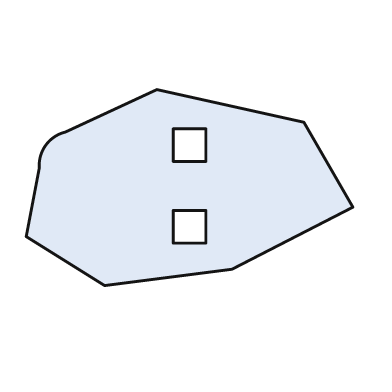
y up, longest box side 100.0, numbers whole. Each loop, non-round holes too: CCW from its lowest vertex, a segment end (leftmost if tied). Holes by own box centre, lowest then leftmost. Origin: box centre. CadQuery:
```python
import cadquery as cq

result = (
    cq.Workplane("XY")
    .moveTo(-26.0, -30.0)
    .lineTo(13.0, -25.0)
    .lineTo(50.0, -6.0)
    .lineTo(35.0, 20.0)
    .lineTo(-10.0, 30.0)
    .lineTo(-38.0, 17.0)
    .threePointArc((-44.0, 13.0), (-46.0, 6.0))
    .lineTo(-50.0, -15.0)
    .close()
    .moveTo(-5.0, -17.0)
    .lineTo(5.0, -17.0)
    .lineTo(5.0, -7.0)
    .lineTo(-5.0, -7.0)
    .close()
    .moveTo(-5.0, 8.0)
    .lineTo(5.0, 8.0)
    .lineTo(5.0, 18.0)
    .lineTo(-5.0, 18.0)
    .close()
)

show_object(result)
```